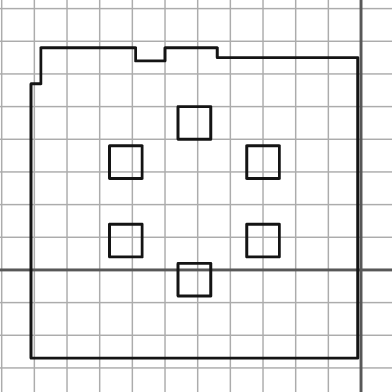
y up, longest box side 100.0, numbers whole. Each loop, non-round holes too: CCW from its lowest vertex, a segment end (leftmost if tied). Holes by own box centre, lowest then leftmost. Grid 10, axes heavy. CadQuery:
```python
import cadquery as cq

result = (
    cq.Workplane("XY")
    .moveTo(-101.0, -27.0)
    .lineTo(-1.0, -27.0)
    .lineTo(-1.0, 65.0)
    .lineTo(-44.0, 65.0)
    .lineTo(-44.0, 68.0)
    .lineTo(-60.0, 68.0)
    .lineTo(-60.0, 64.0)
    .lineTo(-69.0, 64.0)
    .lineTo(-69.0, 68.0)
    .lineTo(-98.0, 68.0)
    .lineTo(-98.0, 57.0)
    .lineTo(-101.0, 57.0)
    .close()
    .moveTo(-56.0, -8.0)
    .lineTo(-46.0, -8.0)
    .lineTo(-46.0, 2.0)
    .lineTo(-56.0, 2.0)
    .close()
    .moveTo(-77.0, 4.0)
    .lineTo(-67.0, 4.0)
    .lineTo(-67.0, 14.0)
    .lineTo(-77.0, 14.0)
    .close()
    .moveTo(-35.0, 4.0)
    .lineTo(-25.0, 4.0)
    .lineTo(-25.0, 14.0)
    .lineTo(-35.0, 14.0)
    .close()
    .moveTo(-77.0, 28.0)
    .lineTo(-67.0, 28.0)
    .lineTo(-67.0, 38.0)
    .lineTo(-77.0, 38.0)
    .close()
    .moveTo(-35.0, 28.0)
    .lineTo(-25.0, 28.0)
    .lineTo(-25.0, 38.0)
    .lineTo(-35.0, 38.0)
    .close()
    .moveTo(-56.0, 40.0)
    .lineTo(-46.0, 40.0)
    .lineTo(-46.0, 50.0)
    .lineTo(-56.0, 50.0)
    .close()
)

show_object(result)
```